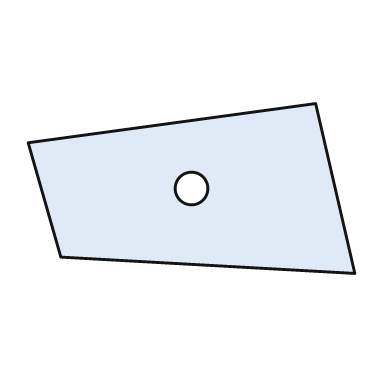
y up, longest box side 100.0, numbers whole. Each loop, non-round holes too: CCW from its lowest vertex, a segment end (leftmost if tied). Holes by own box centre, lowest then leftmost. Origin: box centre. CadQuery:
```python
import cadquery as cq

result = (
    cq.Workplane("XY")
    .moveTo(50.0, -26.0)
    .lineTo(38.0, 26.0)
    .lineTo(-50.0, 14.0)
    .lineTo(-40.0, -21.0)
    .close()
    .moveTo(0.0, 0.0)
    .circle(5.0)
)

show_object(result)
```